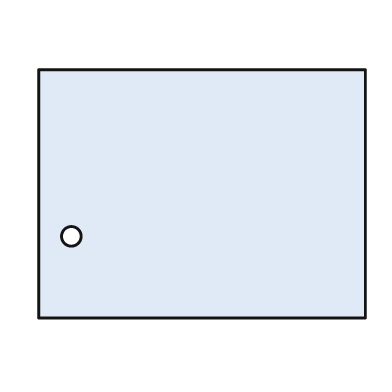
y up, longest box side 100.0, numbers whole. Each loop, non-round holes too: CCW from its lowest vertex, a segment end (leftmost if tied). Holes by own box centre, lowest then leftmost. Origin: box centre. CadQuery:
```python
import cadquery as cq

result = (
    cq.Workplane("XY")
    .moveTo(-50.0, -38.0)
    .lineTo(50.0, -38.0)
    .lineTo(50.0, 38.0)
    .lineTo(-50.0, 38.0)
    .close()
    .moveTo(-40.0, -13.0)
    .circle(3.0)
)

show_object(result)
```